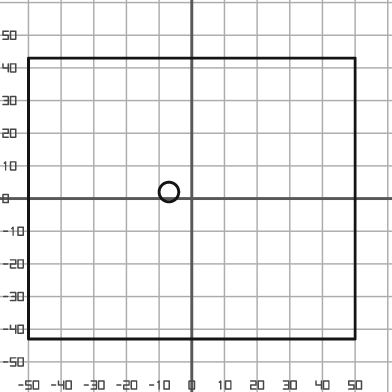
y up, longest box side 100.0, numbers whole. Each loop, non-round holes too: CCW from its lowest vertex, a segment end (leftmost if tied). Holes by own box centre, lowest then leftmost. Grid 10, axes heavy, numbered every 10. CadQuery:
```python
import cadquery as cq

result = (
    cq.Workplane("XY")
    .moveTo(-50.0, -43.0)
    .lineTo(50.0, -43.0)
    .lineTo(50.0, 43.0)
    .lineTo(-50.0, 43.0)
    .close()
    .moveTo(-7.0, 2.0)
    .circle(3.0)
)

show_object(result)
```